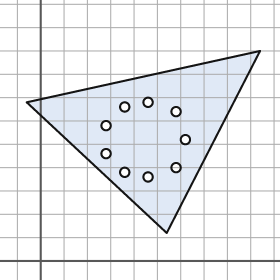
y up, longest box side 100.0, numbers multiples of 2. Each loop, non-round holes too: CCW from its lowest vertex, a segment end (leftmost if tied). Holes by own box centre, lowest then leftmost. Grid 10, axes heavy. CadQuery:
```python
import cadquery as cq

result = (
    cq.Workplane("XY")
    .moveTo(54.0, 12.0)
    .lineTo(94.0, 90.0)
    .lineTo(-6.0, 68.0)
    .close()
    .moveTo(46.0, 36.0)
    .circle(2.0)
    .moveTo(36.0, 38.0)
    .circle(2.0)
    .moveTo(58.0, 40.0)
    .circle(2.0)
    .moveTo(28.0, 46.0)
    .circle(2.0)
    .moveTo(62.0, 52.0)
    .circle(2.0)
    .moveTo(28.0, 58.0)
    .circle(2.0)
    .moveTo(58.0, 64.0)
    .circle(2.0)
    .moveTo(36.0, 66.0)
    .circle(2.0)
    .moveTo(46.0, 68.0)
    .circle(2.0)
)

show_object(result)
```